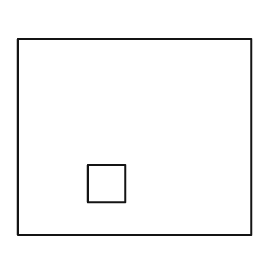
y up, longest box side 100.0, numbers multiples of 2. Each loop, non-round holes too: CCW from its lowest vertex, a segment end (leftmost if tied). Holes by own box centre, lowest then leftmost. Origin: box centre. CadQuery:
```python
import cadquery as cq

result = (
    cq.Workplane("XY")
    .moveTo(-50.0, -42.0)
    .lineTo(50.0, -42.0)
    .lineTo(50.0, 42.0)
    .lineTo(-50.0, 42.0)
    .close()
    .moveTo(-20.0, -28.0)
    .lineTo(-4.0, -28.0)
    .lineTo(-4.0, -12.0)
    .lineTo(-20.0, -12.0)
    .close()
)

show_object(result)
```